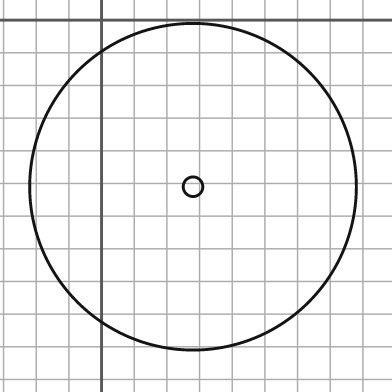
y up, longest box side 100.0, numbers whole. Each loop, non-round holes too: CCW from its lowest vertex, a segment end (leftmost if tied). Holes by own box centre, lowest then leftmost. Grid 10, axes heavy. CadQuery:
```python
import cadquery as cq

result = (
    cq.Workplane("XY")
    .moveTo(28.0, -51.0)
    .circle(50.0)
    .moveTo(28.0, -51.0)
    .circle(3.0)
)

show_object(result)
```